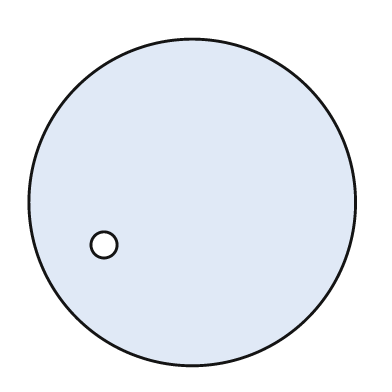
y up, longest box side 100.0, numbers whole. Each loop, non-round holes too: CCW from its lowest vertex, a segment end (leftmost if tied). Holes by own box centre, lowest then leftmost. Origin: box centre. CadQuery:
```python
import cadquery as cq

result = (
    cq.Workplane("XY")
    .moveTo(0.0, 0.0)
    .circle(50.0)
    .moveTo(-27.0, -13.0)
    .circle(4.0)
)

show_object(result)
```